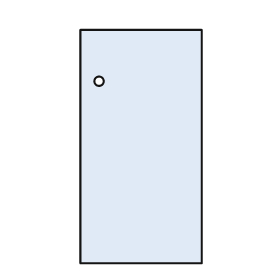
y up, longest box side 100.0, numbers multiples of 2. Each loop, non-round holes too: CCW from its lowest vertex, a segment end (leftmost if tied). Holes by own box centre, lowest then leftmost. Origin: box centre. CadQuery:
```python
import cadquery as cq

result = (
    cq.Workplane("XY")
    .moveTo(-26.0, -50.0)
    .lineTo(26.0, -50.0)
    .lineTo(26.0, 50.0)
    .lineTo(-26.0, 50.0)
    .close()
    .moveTo(-18.0, 28.0)
    .circle(2.0)
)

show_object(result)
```